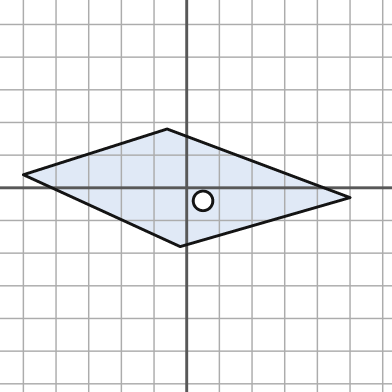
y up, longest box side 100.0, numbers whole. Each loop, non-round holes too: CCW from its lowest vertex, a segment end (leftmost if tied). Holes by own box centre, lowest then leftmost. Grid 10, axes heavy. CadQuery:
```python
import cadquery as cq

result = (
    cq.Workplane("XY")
    .moveTo(-2.0, -18.0)
    .lineTo(50.0, -3.0)
    .lineTo(-6.0, 18.0)
    .lineTo(-50.0, 4.0)
    .close()
    .moveTo(5.0, -4.0)
    .circle(3.0)
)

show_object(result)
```